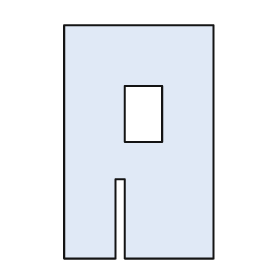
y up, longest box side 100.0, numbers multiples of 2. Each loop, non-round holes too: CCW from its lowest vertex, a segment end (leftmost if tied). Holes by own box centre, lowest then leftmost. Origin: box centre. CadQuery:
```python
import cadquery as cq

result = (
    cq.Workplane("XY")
    .moveTo(-32.0, -50.0)
    .lineTo(-10.0, -50.0)
    .lineTo(-10.0, -16.0)
    .lineTo(-6.0, -16.0)
    .lineTo(-6.0, -50.0)
    .lineTo(32.0, -50.0)
    .lineTo(32.0, 50.0)
    .lineTo(-32.0, 50.0)
    .close()
    .moveTo(-6.0, 0.0)
    .lineTo(10.0, 0.0)
    .lineTo(10.0, 24.0)
    .lineTo(-6.0, 24.0)
    .close()
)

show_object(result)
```